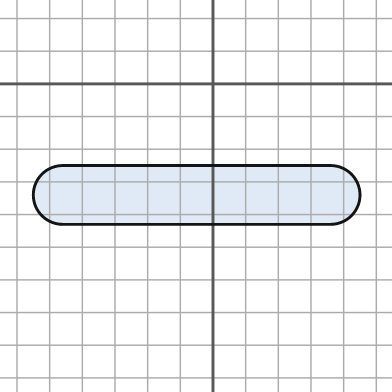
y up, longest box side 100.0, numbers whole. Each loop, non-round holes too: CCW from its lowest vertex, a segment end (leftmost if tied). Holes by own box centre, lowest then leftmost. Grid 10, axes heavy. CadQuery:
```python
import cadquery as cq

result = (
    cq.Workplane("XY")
    .moveTo(-46.0, -43.0)
    .lineTo(36.0, -43.0)
    .threePointArc((45.0, -34.0), (36.0, -25.0))
    .lineTo(-46.0, -25.0)
    .threePointArc((-55.0, -34.0), (-46.0, -43.0))
    .close()
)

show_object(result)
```